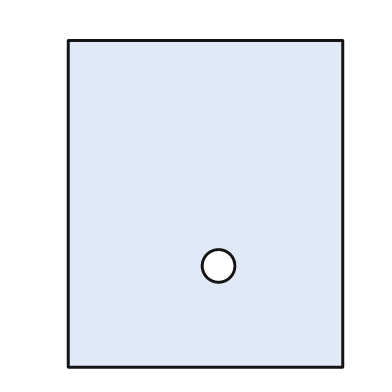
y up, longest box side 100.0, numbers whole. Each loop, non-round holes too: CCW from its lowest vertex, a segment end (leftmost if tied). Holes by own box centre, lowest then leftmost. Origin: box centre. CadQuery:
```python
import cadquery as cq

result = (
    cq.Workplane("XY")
    .moveTo(-42.0, -50.0)
    .lineTo(42.0, -50.0)
    .lineTo(42.0, 50.0)
    .lineTo(-42.0, 50.0)
    .close()
    .moveTo(4.0, -19.0)
    .circle(5.0)
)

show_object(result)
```